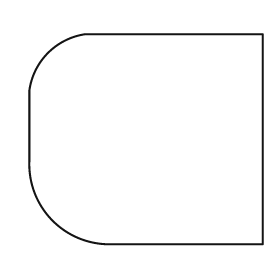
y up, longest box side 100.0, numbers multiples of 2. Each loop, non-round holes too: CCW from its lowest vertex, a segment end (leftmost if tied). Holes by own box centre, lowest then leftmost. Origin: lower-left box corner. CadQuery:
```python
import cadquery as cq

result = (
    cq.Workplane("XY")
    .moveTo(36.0, 0.0)
    .lineTo(100.0, 0.0)
    .lineTo(100.0, 90.0)
    .lineTo(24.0, 90.0)
    .threePointArc((8.0, 82.0), (0.0, 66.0))
    .lineTo(0.0, 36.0)
    .threePointArc((10.0, 10.0), (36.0, 0.0))
    .close()
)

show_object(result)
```